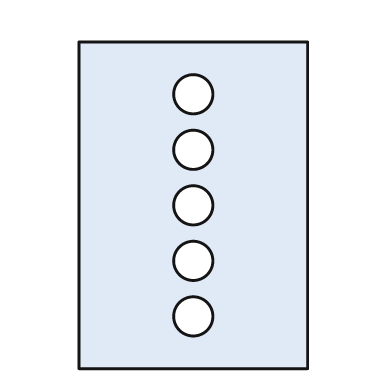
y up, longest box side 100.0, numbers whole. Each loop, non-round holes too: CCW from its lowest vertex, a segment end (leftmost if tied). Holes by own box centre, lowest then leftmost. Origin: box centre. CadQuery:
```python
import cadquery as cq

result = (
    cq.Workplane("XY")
    .moveTo(-35.0, -50.0)
    .lineTo(35.0, -50.0)
    .lineTo(35.0, 50.0)
    .lineTo(-35.0, 50.0)
    .close()
    .moveTo(0.0, -34.0)
    .circle(6.0)
    .moveTo(0.0, -17.0)
    .circle(6.0)
    .moveTo(0.0, 0.0)
    .circle(6.0)
    .moveTo(0.0, 17.0)
    .circle(6.0)
    .moveTo(0.0, 34.0)
    .circle(6.0)
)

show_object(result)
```